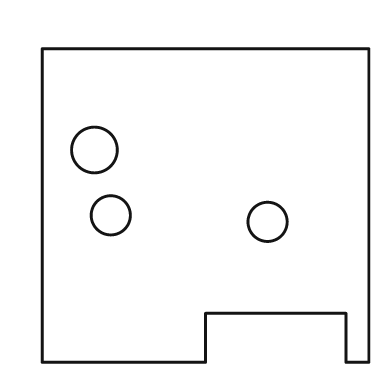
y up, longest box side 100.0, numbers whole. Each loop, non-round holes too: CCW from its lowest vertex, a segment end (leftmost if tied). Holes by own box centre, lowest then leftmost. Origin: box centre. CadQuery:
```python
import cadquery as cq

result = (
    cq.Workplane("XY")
    .moveTo(-50.0, -48.0)
    .lineTo(0.0, -48.0)
    .lineTo(0.0, -33.0)
    .lineTo(43.0, -33.0)
    .lineTo(43.0, -48.0)
    .lineTo(50.0, -48.0)
    .lineTo(50.0, 48.0)
    .lineTo(-50.0, 48.0)
    .close()
    .moveTo(19.0, -5.0)
    .circle(6.0)
    .moveTo(-29.0, -3.0)
    .circle(6.0)
    .moveTo(-34.0, 17.0)
    .circle(7.0)
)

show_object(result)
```